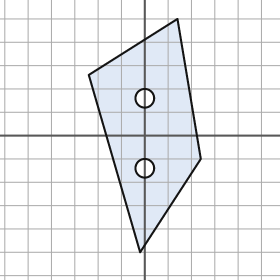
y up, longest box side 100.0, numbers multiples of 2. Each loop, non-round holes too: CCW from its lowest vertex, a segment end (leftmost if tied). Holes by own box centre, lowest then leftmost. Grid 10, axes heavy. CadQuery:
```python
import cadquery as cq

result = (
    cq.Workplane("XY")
    .moveTo(-2.0, -50.0)
    .lineTo(24.0, -10.0)
    .lineTo(14.0, 50.0)
    .lineTo(-24.0, 26.0)
    .close()
    .moveTo(0.0, -14.0)
    .circle(4.0)
    .moveTo(0.0, 16.0)
    .circle(4.0)
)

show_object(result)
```